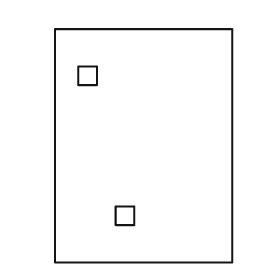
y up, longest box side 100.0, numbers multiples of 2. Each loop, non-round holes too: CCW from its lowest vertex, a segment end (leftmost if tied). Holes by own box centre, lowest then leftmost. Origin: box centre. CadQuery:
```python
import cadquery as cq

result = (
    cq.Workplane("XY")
    .moveTo(-38.0, -50.0)
    .lineTo(38.0, -50.0)
    .lineTo(38.0, 50.0)
    .lineTo(-38.0, 50.0)
    .close()
    .moveTo(-12.0, -34.0)
    .lineTo(-4.0, -34.0)
    .lineTo(-4.0, -26.0)
    .lineTo(-12.0, -26.0)
    .close()
    .moveTo(-28.0, 26.0)
    .lineTo(-20.0, 26.0)
    .lineTo(-20.0, 34.0)
    .lineTo(-28.0, 34.0)
    .close()
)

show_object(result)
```